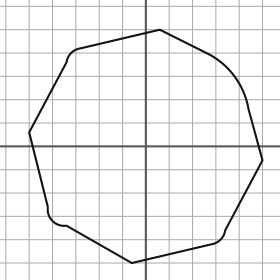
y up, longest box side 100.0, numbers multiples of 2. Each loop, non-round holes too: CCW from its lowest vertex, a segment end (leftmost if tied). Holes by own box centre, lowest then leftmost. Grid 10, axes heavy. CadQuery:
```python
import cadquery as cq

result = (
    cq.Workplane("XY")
    .moveTo(-6.0, -50.0)
    .lineTo(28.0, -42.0)
    .threePointArc((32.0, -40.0), (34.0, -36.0))
    .lineTo(50.0, -6.0)
    .lineTo(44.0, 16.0)
    .threePointArc((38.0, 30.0), (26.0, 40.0))
    .lineTo(6.0, 50.0)
    .lineTo(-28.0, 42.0)
    .threePointArc((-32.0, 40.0), (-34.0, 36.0))
    .lineTo(-50.0, 6.0)
    .lineTo(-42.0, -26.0)
    .threePointArc((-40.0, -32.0), (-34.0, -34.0))
    .close()
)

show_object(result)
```